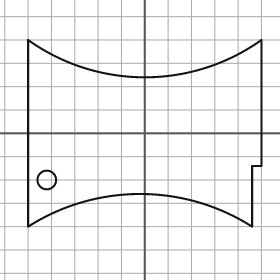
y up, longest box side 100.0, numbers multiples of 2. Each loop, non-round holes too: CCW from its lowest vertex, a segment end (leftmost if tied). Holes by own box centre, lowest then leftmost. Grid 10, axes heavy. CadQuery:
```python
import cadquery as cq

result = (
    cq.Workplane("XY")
    .moveTo(-50.0, -40.0)
    .threePointArc((-2.0, -26.0), (46.0, -40.0))
    .lineTo(46.0, -14.0)
    .lineTo(50.0, -14.0)
    .lineTo(50.0, 40.0)
    .threePointArc((0.0, 24.0), (-50.0, 40.0))
    .close()
    .moveTo(-42.0, -20.0)
    .circle(4.0)
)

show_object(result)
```